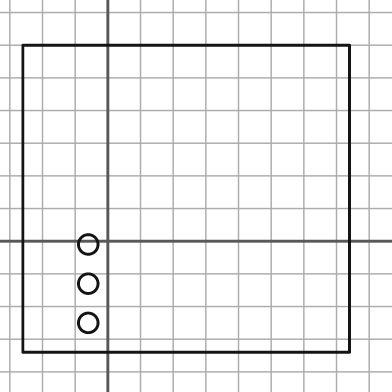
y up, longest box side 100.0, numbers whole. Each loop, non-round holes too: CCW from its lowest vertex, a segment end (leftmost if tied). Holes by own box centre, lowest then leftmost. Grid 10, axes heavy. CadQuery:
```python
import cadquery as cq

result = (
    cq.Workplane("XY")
    .moveTo(-26.0, -34.0)
    .lineTo(74.0, -34.0)
    .lineTo(74.0, 60.0)
    .lineTo(-26.0, 60.0)
    .close()
    .moveTo(-6.0, -25.0)
    .circle(3.0)
    .moveTo(-6.0, -13.0)
    .circle(3.0)
    .moveTo(-6.0, -1.0)
    .circle(3.0)
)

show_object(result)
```